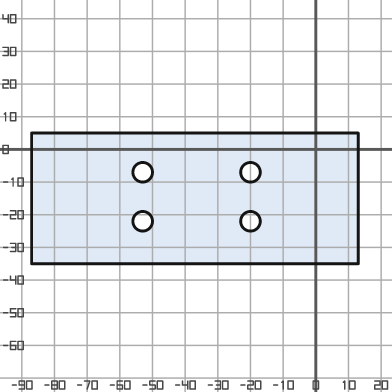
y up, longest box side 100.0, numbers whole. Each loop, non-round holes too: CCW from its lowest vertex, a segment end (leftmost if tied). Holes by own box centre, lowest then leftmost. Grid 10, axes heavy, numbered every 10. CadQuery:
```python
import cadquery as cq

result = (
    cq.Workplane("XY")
    .moveTo(-87.0, -35.0)
    .lineTo(13.0, -35.0)
    .lineTo(13.0, 5.0)
    .lineTo(-87.0, 5.0)
    .close()
    .moveTo(-53.0, -22.0)
    .circle(3.0)
    .moveTo(-20.0, -22.0)
    .circle(3.0)
    .moveTo(-53.0, -7.0)
    .circle(3.0)
    .moveTo(-20.0, -7.0)
    .circle(3.0)
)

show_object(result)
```